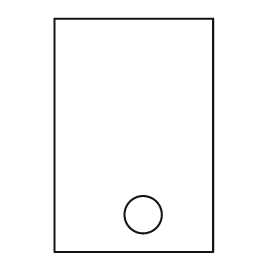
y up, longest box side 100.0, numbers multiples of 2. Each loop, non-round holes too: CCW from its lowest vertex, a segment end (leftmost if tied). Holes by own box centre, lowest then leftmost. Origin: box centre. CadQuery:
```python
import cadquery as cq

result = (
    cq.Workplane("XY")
    .moveTo(-34.0, -50.0)
    .lineTo(34.0, -50.0)
    .lineTo(34.0, 50.0)
    .lineTo(-34.0, 50.0)
    .close()
    .moveTo(4.0, -34.0)
    .circle(8.0)
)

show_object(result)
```